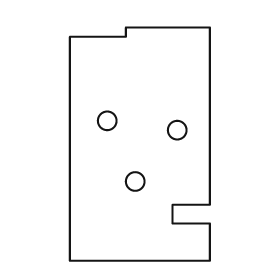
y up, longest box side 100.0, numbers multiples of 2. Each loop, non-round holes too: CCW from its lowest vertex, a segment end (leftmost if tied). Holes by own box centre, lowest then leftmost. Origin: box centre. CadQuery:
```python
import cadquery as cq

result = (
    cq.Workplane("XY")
    .moveTo(-30.0, -50.0)
    .lineTo(30.0, -50.0)
    .lineTo(30.0, -34.0)
    .lineTo(14.0, -34.0)
    .lineTo(14.0, -26.0)
    .lineTo(30.0, -26.0)
    .lineTo(30.0, 50.0)
    .lineTo(-6.0, 50.0)
    .lineTo(-6.0, 46.0)
    .lineTo(-30.0, 46.0)
    .close()
    .moveTo(-2.0, -16.0)
    .circle(4.0)
    .moveTo(16.0, 6.0)
    .circle(4.0)
    .moveTo(-14.0, 10.0)
    .circle(4.0)
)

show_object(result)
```